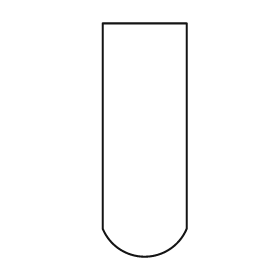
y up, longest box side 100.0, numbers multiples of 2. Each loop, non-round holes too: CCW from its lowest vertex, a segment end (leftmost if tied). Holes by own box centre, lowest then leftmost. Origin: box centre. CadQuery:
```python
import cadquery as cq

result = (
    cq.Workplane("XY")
    .moveTo(-18.0, -38.0)
    .threePointArc((0.0, -50.0), (18.0, -38.0))
    .lineTo(18.0, 50.0)
    .lineTo(-18.0, 50.0)
    .close()
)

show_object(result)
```